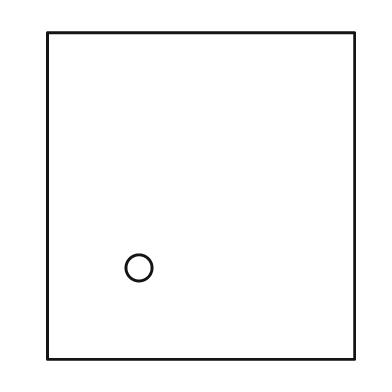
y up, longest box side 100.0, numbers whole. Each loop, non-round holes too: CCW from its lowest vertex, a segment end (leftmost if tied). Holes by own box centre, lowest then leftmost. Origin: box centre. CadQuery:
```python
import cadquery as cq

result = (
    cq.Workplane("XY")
    .moveTo(-47.0, -50.0)
    .lineTo(47.0, -50.0)
    .lineTo(47.0, 50.0)
    .lineTo(-47.0, 50.0)
    .close()
    .moveTo(-19.0, -22.0)
    .circle(4.0)
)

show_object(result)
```